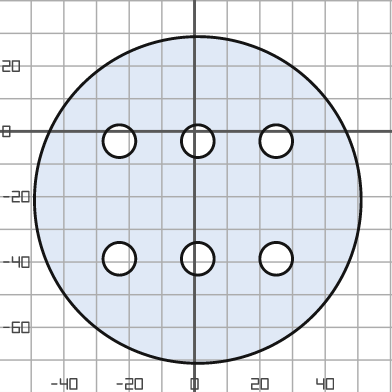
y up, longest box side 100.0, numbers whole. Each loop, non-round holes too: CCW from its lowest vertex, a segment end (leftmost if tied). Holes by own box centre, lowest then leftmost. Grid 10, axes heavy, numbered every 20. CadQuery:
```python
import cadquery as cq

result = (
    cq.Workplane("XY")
    .moveTo(1.0, -21.0)
    .circle(50.0)
    .moveTo(-23.0, -39.0)
    .circle(5.0)
    .moveTo(1.0, -39.0)
    .circle(5.0)
    .moveTo(25.0, -39.0)
    .circle(5.0)
    .moveTo(-23.0, -3.0)
    .circle(5.0)
    .moveTo(1.0, -3.0)
    .circle(5.0)
    .moveTo(25.0, -3.0)
    .circle(5.0)
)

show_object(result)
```